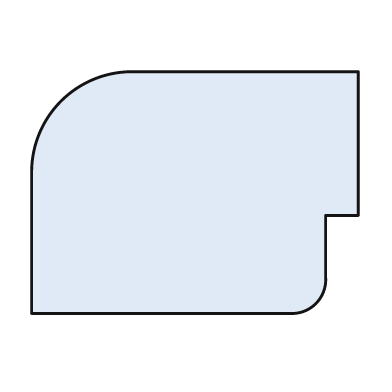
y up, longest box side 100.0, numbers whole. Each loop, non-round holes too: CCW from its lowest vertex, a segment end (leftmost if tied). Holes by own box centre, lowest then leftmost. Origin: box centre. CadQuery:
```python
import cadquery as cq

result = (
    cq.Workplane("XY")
    .moveTo(-50.0, -37.0)
    .lineTo(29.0, -37.0)
    .threePointArc((37.0, -34.0), (40.0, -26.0))
    .lineTo(40.0, -7.0)
    .lineTo(50.0, -7.0)
    .lineTo(50.0, 37.0)
    .lineTo(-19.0, 37.0)
    .threePointArc((-41.0, 28.0), (-50.0, 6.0))
    .close()
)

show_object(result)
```